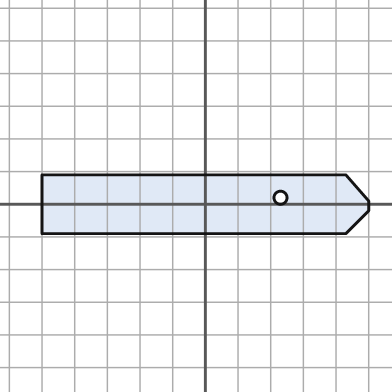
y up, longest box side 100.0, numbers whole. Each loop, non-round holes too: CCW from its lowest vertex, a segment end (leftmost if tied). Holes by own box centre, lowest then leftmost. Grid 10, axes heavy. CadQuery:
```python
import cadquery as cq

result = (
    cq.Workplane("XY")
    .moveTo(-50.0, -9.0)
    .lineTo(43.0, -9.0)
    .lineTo(50.0, -2.0)
    .lineTo(50.0, 1.0)
    .lineTo(43.0, 9.0)
    .lineTo(-50.0, 9.0)
    .close()
    .moveTo(23.0, 2.0)
    .circle(2.0)
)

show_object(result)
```